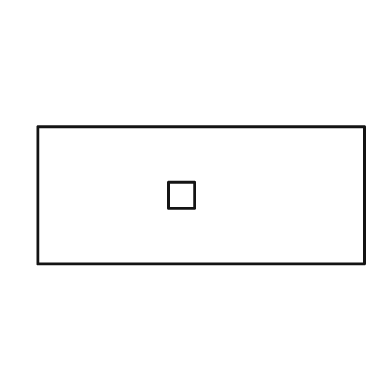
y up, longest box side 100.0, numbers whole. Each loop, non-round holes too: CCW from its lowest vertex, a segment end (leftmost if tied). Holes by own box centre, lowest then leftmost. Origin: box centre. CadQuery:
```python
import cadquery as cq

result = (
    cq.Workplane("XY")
    .moveTo(-50.0, -21.0)
    .lineTo(50.0, -21.0)
    .lineTo(50.0, 21.0)
    .lineTo(-50.0, 21.0)
    .close()
    .moveTo(-10.0, -4.0)
    .lineTo(-2.0, -4.0)
    .lineTo(-2.0, 4.0)
    .lineTo(-10.0, 4.0)
    .close()
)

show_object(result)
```